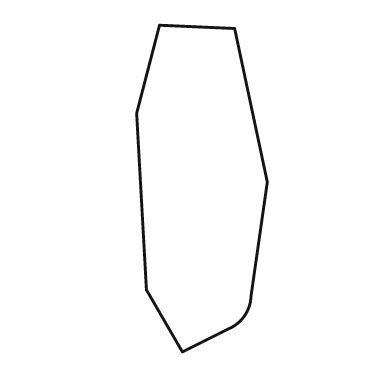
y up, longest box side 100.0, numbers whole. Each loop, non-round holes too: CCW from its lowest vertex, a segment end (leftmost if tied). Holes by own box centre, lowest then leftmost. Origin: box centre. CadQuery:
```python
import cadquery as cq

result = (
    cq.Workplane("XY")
    .moveTo(-6.0, -50.0)
    .lineTo(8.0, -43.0)
    .threePointArc((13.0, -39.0), (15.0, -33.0))
    .lineTo(20.0, 2.0)
    .lineTo(10.0, 49.0)
    .lineTo(-13.0, 50.0)
    .lineTo(-20.0, 23.0)
    .lineTo(-17.0, -31.0)
    .close()
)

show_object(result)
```